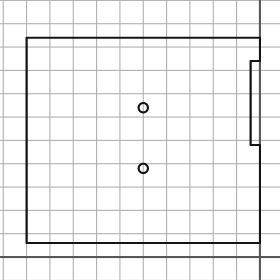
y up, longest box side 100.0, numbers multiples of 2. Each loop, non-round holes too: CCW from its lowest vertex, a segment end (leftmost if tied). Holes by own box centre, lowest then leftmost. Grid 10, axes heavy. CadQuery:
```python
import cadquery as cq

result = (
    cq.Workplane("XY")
    .moveTo(-100.0, 6.0)
    .lineTo(0.0, 6.0)
    .lineTo(0.0, 48.0)
    .lineTo(-4.0, 48.0)
    .lineTo(-4.0, 84.0)
    .lineTo(0.0, 84.0)
    .lineTo(0.0, 94.0)
    .lineTo(-100.0, 94.0)
    .close()
    .moveTo(-50.0, 38.0)
    .circle(2.0)
    .moveTo(-50.0, 64.0)
    .circle(2.0)
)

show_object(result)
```